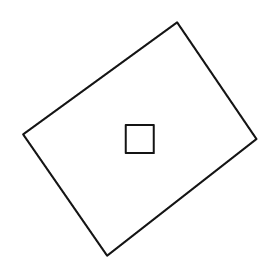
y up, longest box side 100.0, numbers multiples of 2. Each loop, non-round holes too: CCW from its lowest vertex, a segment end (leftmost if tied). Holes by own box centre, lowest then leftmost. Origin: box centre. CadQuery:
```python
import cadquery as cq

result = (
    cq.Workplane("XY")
    .moveTo(-14.0, -50.0)
    .lineTo(50.0, 0.0)
    .lineTo(16.0, 50.0)
    .lineTo(-50.0, 2.0)
    .close()
    .moveTo(-6.0, -6.0)
    .lineTo(6.0, -6.0)
    .lineTo(6.0, 6.0)
    .lineTo(-6.0, 6.0)
    .close()
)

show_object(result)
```